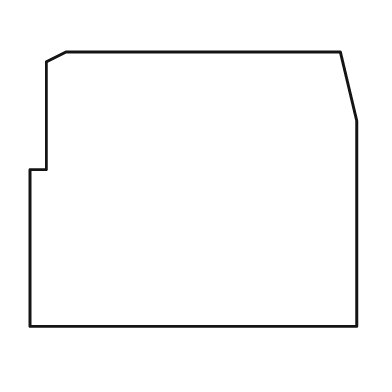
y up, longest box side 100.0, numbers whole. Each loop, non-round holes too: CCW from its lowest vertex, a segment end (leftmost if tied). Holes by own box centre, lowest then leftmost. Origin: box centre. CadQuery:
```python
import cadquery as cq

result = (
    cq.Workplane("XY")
    .moveTo(-50.0, -42.0)
    .lineTo(50.0, -42.0)
    .lineTo(50.0, 21.0)
    .lineTo(45.0, 42.0)
    .lineTo(-39.0, 42.0)
    .lineTo(-45.0, 39.0)
    .lineTo(-45.0, 6.0)
    .lineTo(-50.0, 6.0)
    .close()
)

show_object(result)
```